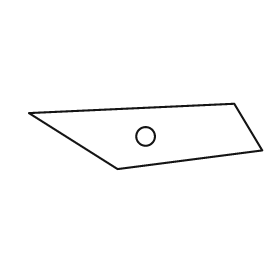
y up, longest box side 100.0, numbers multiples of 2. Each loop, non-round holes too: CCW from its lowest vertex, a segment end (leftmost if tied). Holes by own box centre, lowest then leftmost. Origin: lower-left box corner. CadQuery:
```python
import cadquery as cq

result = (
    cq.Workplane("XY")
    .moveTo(38.0, 0.0)
    .lineTo(100.0, 8.0)
    .lineTo(88.0, 28.0)
    .lineTo(0.0, 24.0)
    .close()
    .moveTo(50.0, 14.0)
    .circle(4.0)
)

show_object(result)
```